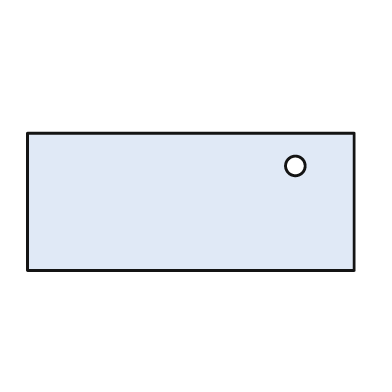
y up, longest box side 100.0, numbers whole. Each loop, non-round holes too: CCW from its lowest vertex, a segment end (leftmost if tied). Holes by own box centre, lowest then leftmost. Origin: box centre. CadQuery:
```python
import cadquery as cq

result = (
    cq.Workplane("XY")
    .moveTo(-50.0, -21.0)
    .lineTo(50.0, -21.0)
    .lineTo(50.0, 21.0)
    .lineTo(-50.0, 21.0)
    .close()
    .moveTo(32.0, 11.0)
    .circle(3.0)
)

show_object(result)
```